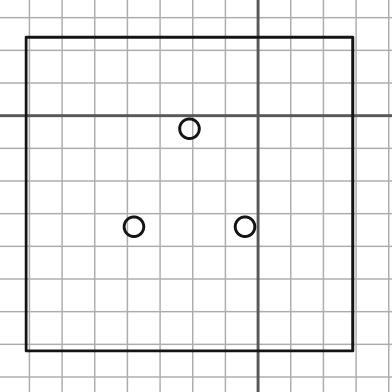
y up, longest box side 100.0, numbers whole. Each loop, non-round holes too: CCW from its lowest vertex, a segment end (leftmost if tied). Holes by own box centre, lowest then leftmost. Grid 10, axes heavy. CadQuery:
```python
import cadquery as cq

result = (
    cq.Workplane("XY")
    .moveTo(-71.0, -72.0)
    .lineTo(29.0, -72.0)
    .lineTo(29.0, 24.0)
    .lineTo(-71.0, 24.0)
    .close()
    .moveTo(-38.0, -34.0)
    .circle(3.0)
    .moveTo(-4.0, -34.0)
    .circle(3.0)
    .moveTo(-21.0, -4.0)
    .circle(3.0)
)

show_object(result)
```